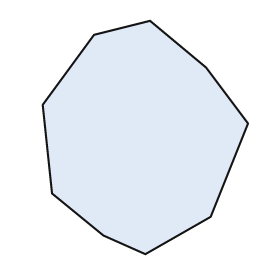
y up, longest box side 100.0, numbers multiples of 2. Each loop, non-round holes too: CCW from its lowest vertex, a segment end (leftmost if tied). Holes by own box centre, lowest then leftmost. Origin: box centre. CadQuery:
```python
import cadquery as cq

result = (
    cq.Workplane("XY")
    .moveTo(0.0, -50.0)
    .lineTo(28.0, -34.0)
    .lineTo(44.0, 6.0)
    .lineTo(26.0, 30.0)
    .lineTo(2.0, 50.0)
    .lineTo(-22.0, 44.0)
    .lineTo(-44.0, 14.0)
    .lineTo(-40.0, -24.0)
    .lineTo(-18.0, -42.0)
    .close()
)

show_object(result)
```